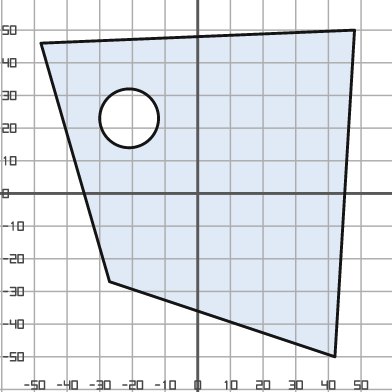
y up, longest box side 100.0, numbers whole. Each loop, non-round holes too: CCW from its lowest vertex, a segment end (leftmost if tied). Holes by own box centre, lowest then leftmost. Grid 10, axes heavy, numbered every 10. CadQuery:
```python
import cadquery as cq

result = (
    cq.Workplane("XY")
    .moveTo(42.0, -50.0)
    .lineTo(48.0, 50.0)
    .lineTo(-48.0, 46.0)
    .lineTo(-27.0, -27.0)
    .close()
    .moveTo(-21.0, 23.0)
    .circle(9.0)
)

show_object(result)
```